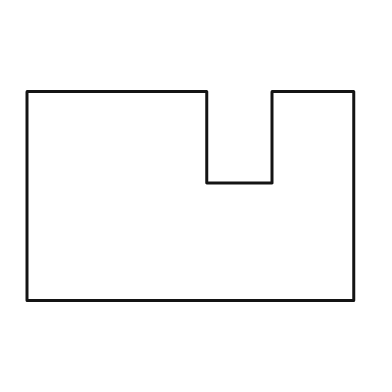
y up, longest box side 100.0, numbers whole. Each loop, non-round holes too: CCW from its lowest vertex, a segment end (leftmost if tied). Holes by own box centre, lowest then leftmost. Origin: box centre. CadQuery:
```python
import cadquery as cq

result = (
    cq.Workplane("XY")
    .moveTo(-50.0, -32.0)
    .lineTo(50.0, -32.0)
    .lineTo(50.0, 32.0)
    .lineTo(25.0, 32.0)
    .lineTo(25.0, 4.0)
    .lineTo(5.0, 4.0)
    .lineTo(5.0, 32.0)
    .lineTo(-50.0, 32.0)
    .close()
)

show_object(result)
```